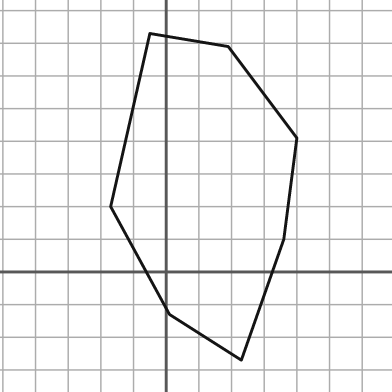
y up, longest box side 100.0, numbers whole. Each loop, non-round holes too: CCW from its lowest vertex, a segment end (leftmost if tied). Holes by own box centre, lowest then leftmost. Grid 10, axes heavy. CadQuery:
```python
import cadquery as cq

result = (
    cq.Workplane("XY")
    .moveTo(23.0, -27.0)
    .lineTo(36.0, 10.0)
    .lineTo(40.0, 41.0)
    .lineTo(19.0, 69.0)
    .lineTo(-5.0, 73.0)
    .lineTo(-17.0, 20.0)
    .lineTo(1.0, -13.0)
    .close()
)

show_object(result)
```